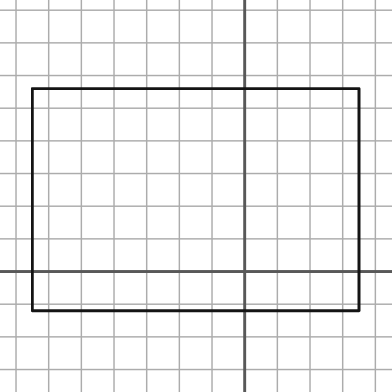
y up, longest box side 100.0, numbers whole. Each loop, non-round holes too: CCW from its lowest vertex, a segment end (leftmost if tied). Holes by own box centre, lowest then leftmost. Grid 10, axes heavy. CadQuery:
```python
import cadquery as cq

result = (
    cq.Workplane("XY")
    .moveTo(-65.0, -12.0)
    .lineTo(35.0, -12.0)
    .lineTo(35.0, 56.0)
    .lineTo(-65.0, 56.0)
    .close()
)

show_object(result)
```